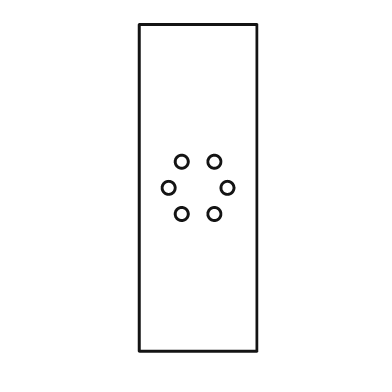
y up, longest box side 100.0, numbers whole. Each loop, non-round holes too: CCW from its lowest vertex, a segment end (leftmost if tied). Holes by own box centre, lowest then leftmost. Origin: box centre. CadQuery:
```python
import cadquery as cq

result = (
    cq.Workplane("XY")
    .moveTo(-18.0, -50.0)
    .lineTo(18.0, -50.0)
    .lineTo(18.0, 50.0)
    .lineTo(-18.0, 50.0)
    .close()
    .moveTo(-5.0, -8.0)
    .circle(2.0)
    .moveTo(5.0, -8.0)
    .circle(2.0)
    .moveTo(-9.0, 0.0)
    .circle(2.0)
    .moveTo(9.0, 0.0)
    .circle(2.0)
    .moveTo(-5.0, 8.0)
    .circle(2.0)
    .moveTo(5.0, 8.0)
    .circle(2.0)
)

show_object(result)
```